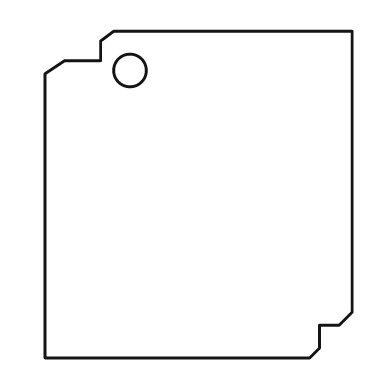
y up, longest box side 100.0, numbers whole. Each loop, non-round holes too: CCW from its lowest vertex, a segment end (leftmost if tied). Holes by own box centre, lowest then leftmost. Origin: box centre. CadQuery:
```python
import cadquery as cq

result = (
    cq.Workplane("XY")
    .moveTo(-47.0, -50.0)
    .lineTo(34.0, -50.0)
    .lineTo(37.0, -47.0)
    .lineTo(37.0, -40.0)
    .lineTo(43.0, -40.0)
    .lineTo(47.0, -36.0)
    .lineTo(47.0, 50.0)
    .lineTo(-26.0, 50.0)
    .lineTo(-30.0, 47.0)
    .lineTo(-30.0, 41.0)
    .lineTo(-41.0, 41.0)
    .lineTo(-47.0, 37.0)
    .close()
    .moveTo(-21.0, 38.0)
    .circle(5.0)
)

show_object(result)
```